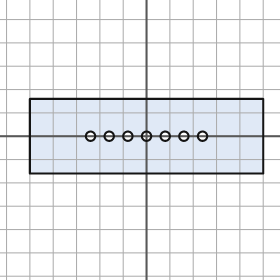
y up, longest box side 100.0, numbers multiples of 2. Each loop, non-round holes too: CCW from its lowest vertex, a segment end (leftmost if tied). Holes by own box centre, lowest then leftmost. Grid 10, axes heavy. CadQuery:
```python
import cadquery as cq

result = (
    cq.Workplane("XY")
    .moveTo(-50.0, -16.0)
    .lineTo(50.0, -16.0)
    .lineTo(50.0, 16.0)
    .lineTo(-50.0, 16.0)
    .close()
    .moveTo(-24.0, 0.0)
    .circle(2.0)
    .moveTo(-16.0, 0.0)
    .circle(2.0)
    .moveTo(-8.0, 0.0)
    .circle(2.0)
    .moveTo(0.0, 0.0)
    .circle(2.0)
    .moveTo(8.0, 0.0)
    .circle(2.0)
    .moveTo(16.0, 0.0)
    .circle(2.0)
    .moveTo(24.0, 0.0)
    .circle(2.0)
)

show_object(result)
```